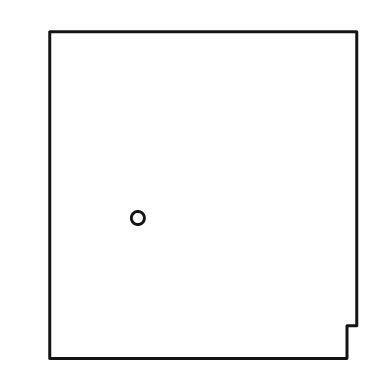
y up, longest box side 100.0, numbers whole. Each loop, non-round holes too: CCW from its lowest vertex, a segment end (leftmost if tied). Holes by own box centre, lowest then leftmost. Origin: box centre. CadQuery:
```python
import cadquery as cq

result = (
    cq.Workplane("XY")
    .moveTo(-47.0, -50.0)
    .lineTo(44.0, -50.0)
    .lineTo(44.0, -40.0)
    .lineTo(47.0, -40.0)
    .lineTo(47.0, 50.0)
    .lineTo(-47.0, 50.0)
    .close()
    .moveTo(-20.0, -7.0)
    .circle(2.0)
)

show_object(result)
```